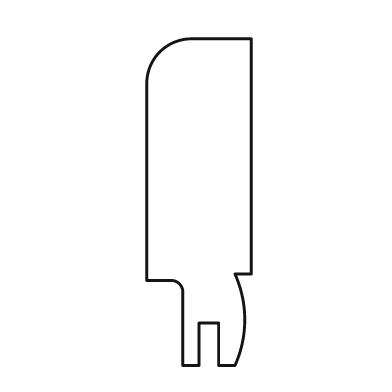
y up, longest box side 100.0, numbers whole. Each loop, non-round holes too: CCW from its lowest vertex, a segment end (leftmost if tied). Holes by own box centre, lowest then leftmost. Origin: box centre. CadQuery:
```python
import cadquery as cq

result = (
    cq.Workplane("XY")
    .moveTo(-5.0, -50.0)
    .lineTo(0.0, -50.0)
    .lineTo(0.0, -37.0)
    .lineTo(6.0, -37.0)
    .lineTo(6.0, -50.0)
    .lineTo(11.0, -50.0)
    .threePointArc((14.0, -36.0), (11.0, -22.0))
    .lineTo(16.0, -22.0)
    .lineTo(16.0, 50.0)
    .lineTo(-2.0, 50.0)
    .threePointArc((-12.0, 46.0), (-16.0, 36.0))
    .lineTo(-16.0, -24.0)
    .lineTo(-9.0, -24.0)
    .threePointArc((-6.0, -25.0), (-5.0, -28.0))
    .close()
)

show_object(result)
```